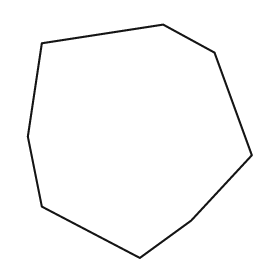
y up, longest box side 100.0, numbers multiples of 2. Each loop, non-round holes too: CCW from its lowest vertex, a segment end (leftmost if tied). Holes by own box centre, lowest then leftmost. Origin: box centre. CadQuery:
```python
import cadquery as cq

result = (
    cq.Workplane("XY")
    .moveTo(0.0, -50.0)
    .lineTo(22.0, -34.0)
    .lineTo(48.0, -6.0)
    .lineTo(32.0, 38.0)
    .lineTo(10.0, 50.0)
    .lineTo(-42.0, 42.0)
    .lineTo(-48.0, 2.0)
    .lineTo(-42.0, -28.0)
    .close()
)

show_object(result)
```